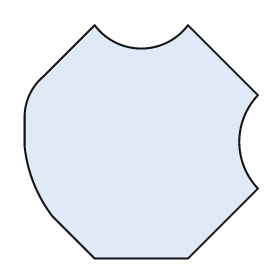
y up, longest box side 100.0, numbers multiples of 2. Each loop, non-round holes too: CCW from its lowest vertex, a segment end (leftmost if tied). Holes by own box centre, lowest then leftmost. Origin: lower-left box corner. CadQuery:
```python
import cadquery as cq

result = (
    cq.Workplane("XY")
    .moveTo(30.0, 0.0)
    .lineTo(70.0, 0.0)
    .lineTo(100.0, 30.0)
    .threePointArc((92.0, 50.0), (100.0, 70.0))
    .lineTo(70.0, 100.0)
    .threePointArc((50.0, 90.0), (30.0, 100.0))
    .lineTo(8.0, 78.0)
    .threePointArc((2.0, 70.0), (0.0, 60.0))
    .lineTo(0.0, 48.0)
    .threePointArc((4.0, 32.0), (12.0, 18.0))
    .close()
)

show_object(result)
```